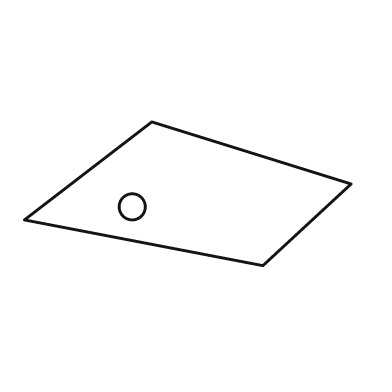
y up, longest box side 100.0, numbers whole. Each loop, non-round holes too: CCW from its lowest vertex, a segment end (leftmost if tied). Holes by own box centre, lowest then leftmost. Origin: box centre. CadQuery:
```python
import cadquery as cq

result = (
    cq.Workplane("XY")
    .moveTo(23.0, -22.0)
    .lineTo(50.0, 3.0)
    .lineTo(-11.0, 22.0)
    .lineTo(-50.0, -8.0)
    .close()
    .moveTo(-17.0, -4.0)
    .circle(4.0)
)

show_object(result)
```